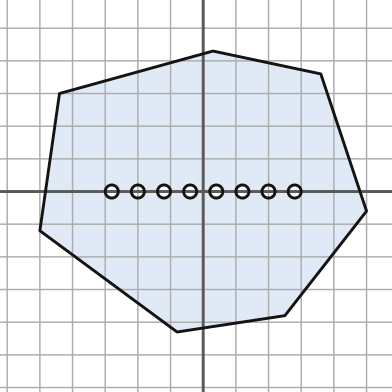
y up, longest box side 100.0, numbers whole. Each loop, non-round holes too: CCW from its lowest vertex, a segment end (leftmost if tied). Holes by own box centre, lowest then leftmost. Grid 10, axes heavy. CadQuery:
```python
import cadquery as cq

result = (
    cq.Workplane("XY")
    .moveTo(-8.0, -43.0)
    .lineTo(25.0, -38.0)
    .lineTo(50.0, -6.0)
    .lineTo(36.0, 36.0)
    .lineTo(3.0, 43.0)
    .lineTo(-44.0, 30.0)
    .lineTo(-50.0, -12.0)
    .close()
    .moveTo(-28.0, 0.0)
    .circle(2.0)
    .moveTo(-20.0, 0.0)
    .circle(2.0)
    .moveTo(-12.0, 0.0)
    .circle(2.0)
    .moveTo(-4.0, 0.0)
    .circle(2.0)
    .moveTo(4.0, 0.0)
    .circle(2.0)
    .moveTo(12.0, 0.0)
    .circle(2.0)
    .moveTo(20.0, 0.0)
    .circle(2.0)
    .moveTo(28.0, 0.0)
    .circle(2.0)
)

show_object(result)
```